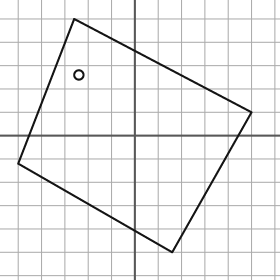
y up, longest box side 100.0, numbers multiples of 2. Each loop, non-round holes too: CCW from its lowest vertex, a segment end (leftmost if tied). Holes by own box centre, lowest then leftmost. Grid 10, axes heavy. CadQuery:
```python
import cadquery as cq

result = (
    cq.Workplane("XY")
    .moveTo(16.0, -50.0)
    .lineTo(50.0, 10.0)
    .lineTo(-26.0, 50.0)
    .lineTo(-50.0, -12.0)
    .close()
    .moveTo(-24.0, 26.0)
    .circle(2.0)
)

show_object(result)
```